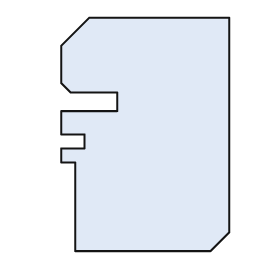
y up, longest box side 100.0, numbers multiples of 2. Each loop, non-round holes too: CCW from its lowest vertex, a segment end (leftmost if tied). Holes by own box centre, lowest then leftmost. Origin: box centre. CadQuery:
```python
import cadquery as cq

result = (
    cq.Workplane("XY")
    .moveTo(-30.0, -50.0)
    .lineTo(28.0, -50.0)
    .lineTo(36.0, -42.0)
    .lineTo(36.0, 50.0)
    .lineTo(-24.0, 50.0)
    .lineTo(-36.0, 38.0)
    .lineTo(-36.0, 22.0)
    .lineTo(-32.0, 18.0)
    .lineTo(-12.0, 18.0)
    .lineTo(-12.0, 10.0)
    .lineTo(-36.0, 10.0)
    .lineTo(-36.0, 0.0)
    .lineTo(-26.0, 0.0)
    .lineTo(-26.0, -6.0)
    .lineTo(-36.0, -6.0)
    .lineTo(-36.0, -12.0)
    .lineTo(-30.0, -12.0)
    .close()
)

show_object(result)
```